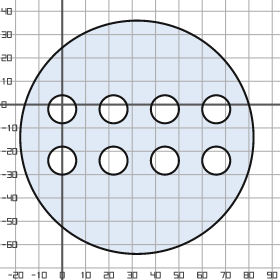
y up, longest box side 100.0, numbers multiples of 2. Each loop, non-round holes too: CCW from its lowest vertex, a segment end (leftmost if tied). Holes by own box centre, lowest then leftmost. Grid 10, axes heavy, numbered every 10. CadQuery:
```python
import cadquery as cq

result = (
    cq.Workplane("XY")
    .moveTo(32.0, -14.0)
    .circle(50.0)
    .moveTo(0.0, -24.0)
    .circle(6.0)
    .moveTo(22.0, -24.0)
    .circle(6.0)
    .moveTo(44.0, -24.0)
    .circle(6.0)
    .moveTo(66.0, -24.0)
    .circle(6.0)
    .moveTo(0.0, -2.0)
    .circle(6.0)
    .moveTo(22.0, -2.0)
    .circle(6.0)
    .moveTo(44.0, -2.0)
    .circle(6.0)
    .moveTo(66.0, -2.0)
    .circle(6.0)
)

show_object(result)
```